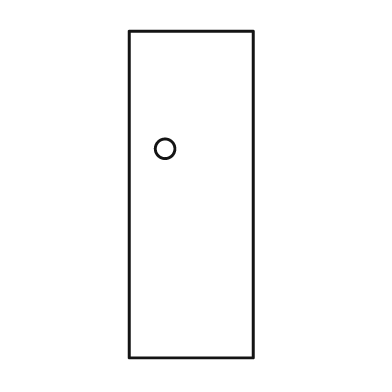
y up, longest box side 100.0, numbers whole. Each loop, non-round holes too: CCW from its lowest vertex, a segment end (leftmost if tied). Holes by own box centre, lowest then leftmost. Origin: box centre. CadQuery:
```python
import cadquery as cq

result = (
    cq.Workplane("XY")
    .moveTo(-19.0, -50.0)
    .lineTo(19.0, -50.0)
    .lineTo(19.0, 50.0)
    .lineTo(-19.0, 50.0)
    .close()
    .moveTo(-8.0, 14.0)
    .circle(3.0)
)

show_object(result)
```